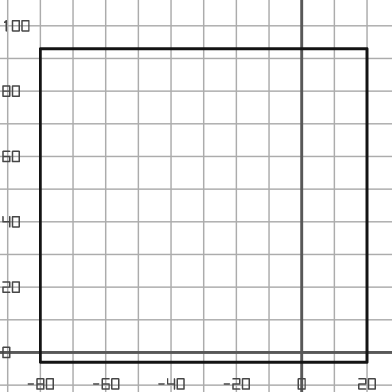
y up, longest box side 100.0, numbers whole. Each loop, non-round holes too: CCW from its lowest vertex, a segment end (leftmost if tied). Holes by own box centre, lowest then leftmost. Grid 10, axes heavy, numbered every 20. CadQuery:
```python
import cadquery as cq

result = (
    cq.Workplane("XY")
    .moveTo(-80.0, -3.0)
    .lineTo(20.0, -3.0)
    .lineTo(20.0, 93.0)
    .lineTo(-80.0, 93.0)
    .close()
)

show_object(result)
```